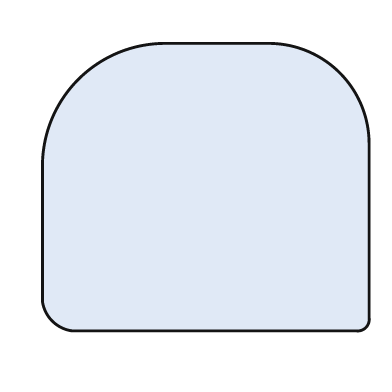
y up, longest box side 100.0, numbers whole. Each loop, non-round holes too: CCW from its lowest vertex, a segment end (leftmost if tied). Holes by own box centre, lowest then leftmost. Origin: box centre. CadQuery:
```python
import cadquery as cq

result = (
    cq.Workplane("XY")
    .moveTo(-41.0, -44.0)
    .lineTo(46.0, -44.0)
    .threePointArc((49.0, -43.0), (50.0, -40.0))
    .lineTo(50.0, 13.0)
    .threePointArc((41.0, 35.0), (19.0, 44.0))
    .lineTo(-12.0, 44.0)
    .threePointArc((-39.0, 33.0), (-50.0, 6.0))
    .lineTo(-50.0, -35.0)
    .threePointArc((-47.0, -41.0), (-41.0, -44.0))
    .close()
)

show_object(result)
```